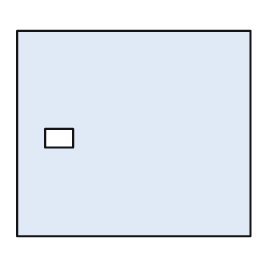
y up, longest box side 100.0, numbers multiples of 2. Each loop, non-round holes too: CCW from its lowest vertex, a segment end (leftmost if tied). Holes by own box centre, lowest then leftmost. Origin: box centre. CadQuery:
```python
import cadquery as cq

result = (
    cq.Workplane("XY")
    .moveTo(-50.0, -44.0)
    .lineTo(50.0, -44.0)
    .lineTo(50.0, 44.0)
    .lineTo(-50.0, 44.0)
    .close()
    .moveTo(-38.0, -6.0)
    .lineTo(-26.0, -6.0)
    .lineTo(-26.0, 2.0)
    .lineTo(-38.0, 2.0)
    .close()
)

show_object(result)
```